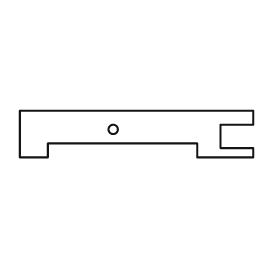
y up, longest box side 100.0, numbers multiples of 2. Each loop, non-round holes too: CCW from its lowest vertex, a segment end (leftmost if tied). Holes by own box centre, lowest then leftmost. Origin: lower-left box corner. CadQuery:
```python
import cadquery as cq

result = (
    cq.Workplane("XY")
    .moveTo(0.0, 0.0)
    .lineTo(12.0, 0.0)
    .lineTo(12.0, 6.0)
    .lineTo(76.0, 6.0)
    .lineTo(76.0, 0.0)
    .lineTo(100.0, 0.0)
    .lineTo(100.0, 4.0)
    .lineTo(86.0, 4.0)
    .lineTo(86.0, 14.0)
    .lineTo(100.0, 14.0)
    .lineTo(100.0, 20.0)
    .lineTo(0.0, 20.0)
    .close()
    .moveTo(40.0, 12.0)
    .circle(2.0)
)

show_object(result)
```